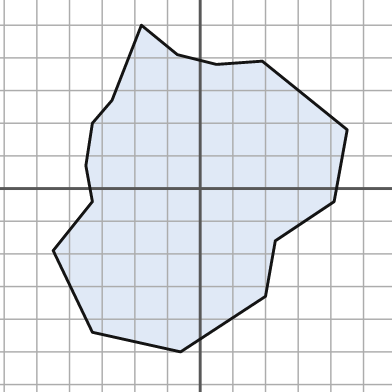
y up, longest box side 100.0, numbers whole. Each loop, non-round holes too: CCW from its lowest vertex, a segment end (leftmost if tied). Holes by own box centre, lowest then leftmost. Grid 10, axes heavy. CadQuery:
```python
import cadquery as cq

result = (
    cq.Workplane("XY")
    .moveTo(-6.0, -50.0)
    .lineTo(20.0, -33.0)
    .lineTo(23.0, -16.0)
    .lineTo(41.0, -4.0)
    .lineTo(45.0, 18.0)
    .lineTo(19.0, 39.0)
    .lineTo(5.0, 38.0)
    .lineTo(-7.0, 41.0)
    .lineTo(-18.0, 50.0)
    .lineTo(-27.0, 27.0)
    .lineTo(-33.0, 20.0)
    .lineTo(-35.0, 7.0)
    .lineTo(-33.0, -4.0)
    .lineTo(-45.0, -19.0)
    .lineTo(-33.0, -44.0)
    .close()
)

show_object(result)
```